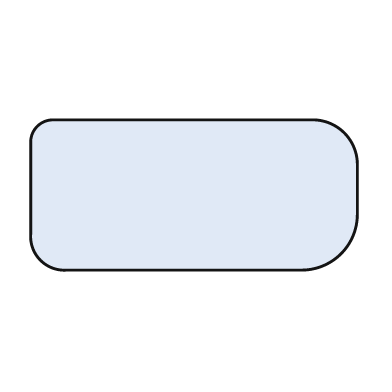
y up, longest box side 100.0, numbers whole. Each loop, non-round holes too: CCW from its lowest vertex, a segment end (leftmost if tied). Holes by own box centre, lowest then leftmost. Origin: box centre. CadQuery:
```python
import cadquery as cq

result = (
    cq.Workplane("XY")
    .moveTo(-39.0, -23.0)
    .lineTo(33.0, -23.0)
    .threePointArc((45.0, -18.0), (50.0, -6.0))
    .lineTo(50.0, 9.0)
    .threePointArc((46.0, 19.0), (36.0, 23.0))
    .lineTo(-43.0, 23.0)
    .threePointArc((-48.0, 21.0), (-50.0, 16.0))
    .lineTo(-50.0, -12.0)
    .threePointArc((-47.0, -20.0), (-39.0, -23.0))
    .close()
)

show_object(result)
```